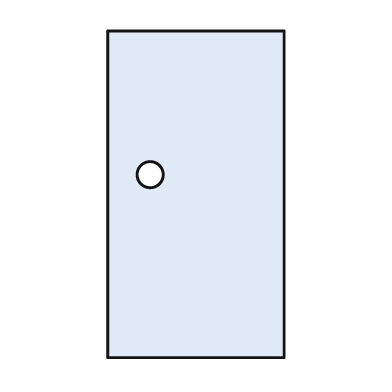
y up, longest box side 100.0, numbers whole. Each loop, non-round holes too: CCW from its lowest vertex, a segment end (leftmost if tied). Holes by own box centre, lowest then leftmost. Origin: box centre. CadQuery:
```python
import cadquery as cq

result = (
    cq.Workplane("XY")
    .moveTo(-27.0, -50.0)
    .lineTo(27.0, -50.0)
    .lineTo(27.0, 50.0)
    .lineTo(-27.0, 50.0)
    .close()
    .moveTo(-14.0, 6.0)
    .circle(4.0)
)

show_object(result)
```